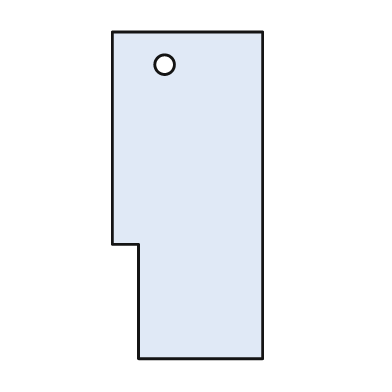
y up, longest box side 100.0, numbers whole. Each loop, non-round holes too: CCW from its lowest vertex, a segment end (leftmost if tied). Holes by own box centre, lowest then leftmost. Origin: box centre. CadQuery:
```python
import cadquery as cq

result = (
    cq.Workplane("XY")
    .moveTo(-15.0, -50.0)
    .lineTo(23.0, -50.0)
    .lineTo(23.0, 50.0)
    .lineTo(-23.0, 50.0)
    .lineTo(-23.0, -15.0)
    .lineTo(-15.0, -15.0)
    .close()
    .moveTo(-7.0, 40.0)
    .circle(3.0)
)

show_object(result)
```